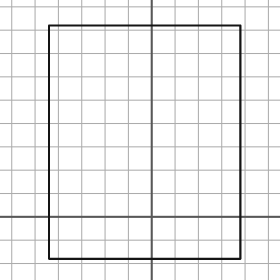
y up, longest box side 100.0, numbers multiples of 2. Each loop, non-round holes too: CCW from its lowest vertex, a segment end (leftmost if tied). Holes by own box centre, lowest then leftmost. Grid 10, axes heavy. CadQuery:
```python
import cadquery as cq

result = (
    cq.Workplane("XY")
    .moveTo(-44.0, -18.0)
    .lineTo(38.0, -18.0)
    .lineTo(38.0, 82.0)
    .lineTo(-44.0, 82.0)
    .close()
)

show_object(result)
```